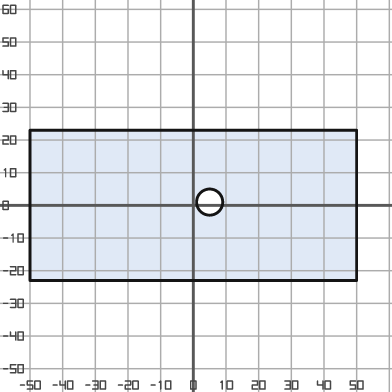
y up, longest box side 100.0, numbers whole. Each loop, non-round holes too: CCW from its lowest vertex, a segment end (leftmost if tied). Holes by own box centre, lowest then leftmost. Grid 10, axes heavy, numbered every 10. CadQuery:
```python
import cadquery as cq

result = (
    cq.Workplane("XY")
    .moveTo(-50.0, -23.0)
    .lineTo(50.0, -23.0)
    .lineTo(50.0, 23.0)
    .lineTo(-50.0, 23.0)
    .close()
    .moveTo(5.0, 1.0)
    .circle(4.0)
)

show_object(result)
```